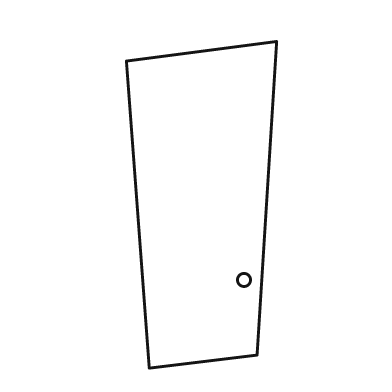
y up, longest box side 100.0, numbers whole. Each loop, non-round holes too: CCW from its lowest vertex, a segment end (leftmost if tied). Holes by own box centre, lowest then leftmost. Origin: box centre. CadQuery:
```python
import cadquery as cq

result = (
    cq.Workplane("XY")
    .moveTo(-16.0, -50.0)
    .lineTo(17.0, -46.0)
    .lineTo(23.0, 50.0)
    .lineTo(-23.0, 44.0)
    .close()
    .moveTo(13.0, -23.0)
    .circle(2.0)
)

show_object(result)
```